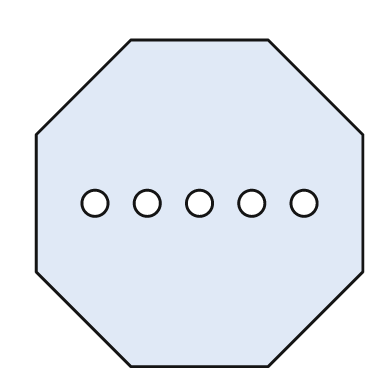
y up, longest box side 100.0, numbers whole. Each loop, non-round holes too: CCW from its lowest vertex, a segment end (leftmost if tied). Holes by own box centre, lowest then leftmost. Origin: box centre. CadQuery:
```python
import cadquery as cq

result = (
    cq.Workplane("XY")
    .moveTo(-21.0, -50.0)
    .lineTo(21.0, -50.0)
    .lineTo(50.0, -21.0)
    .lineTo(50.0, 21.0)
    .lineTo(21.0, 50.0)
    .lineTo(-21.0, 50.0)
    .lineTo(-50.0, 21.0)
    .lineTo(-50.0, -21.0)
    .close()
    .moveTo(-32.0, 0.0)
    .circle(4.0)
    .moveTo(-16.0, 0.0)
    .circle(4.0)
    .moveTo(0.0, 0.0)
    .circle(4.0)
    .moveTo(16.0, 0.0)
    .circle(4.0)
    .moveTo(32.0, 0.0)
    .circle(4.0)
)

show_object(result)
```